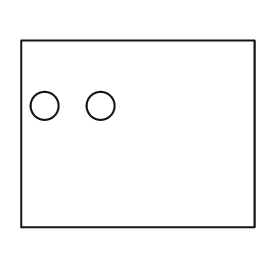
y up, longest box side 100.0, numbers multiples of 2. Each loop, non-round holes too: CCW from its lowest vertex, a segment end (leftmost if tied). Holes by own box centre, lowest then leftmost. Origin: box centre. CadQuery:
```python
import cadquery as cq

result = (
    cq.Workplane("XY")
    .moveTo(-50.0, -40.0)
    .lineTo(50.0, -40.0)
    .lineTo(50.0, 40.0)
    .lineTo(-50.0, 40.0)
    .close()
    .moveTo(-40.0, 12.0)
    .circle(6.0)
    .moveTo(-16.0, 12.0)
    .circle(6.0)
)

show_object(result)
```